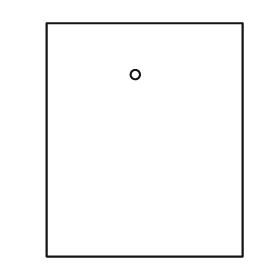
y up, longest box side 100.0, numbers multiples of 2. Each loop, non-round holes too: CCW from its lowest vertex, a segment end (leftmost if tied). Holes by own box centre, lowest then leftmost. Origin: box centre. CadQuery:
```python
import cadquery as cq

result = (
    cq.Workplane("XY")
    .moveTo(-42.0, -50.0)
    .lineTo(42.0, -50.0)
    .lineTo(42.0, 50.0)
    .lineTo(-42.0, 50.0)
    .close()
    .moveTo(-4.0, 28.0)
    .circle(2.0)
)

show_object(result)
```